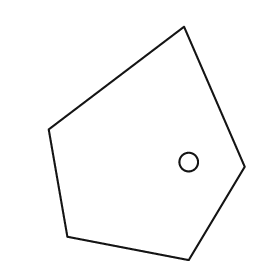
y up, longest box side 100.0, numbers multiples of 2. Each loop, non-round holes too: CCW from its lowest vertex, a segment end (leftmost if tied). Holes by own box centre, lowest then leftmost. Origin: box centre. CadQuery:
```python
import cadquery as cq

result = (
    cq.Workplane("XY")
    .moveTo(18.0, -50.0)
    .lineTo(42.0, -10.0)
    .lineTo(16.0, 50.0)
    .lineTo(-42.0, 6.0)
    .lineTo(-34.0, -40.0)
    .close()
    .moveTo(18.0, -8.0)
    .circle(4.0)
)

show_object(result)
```